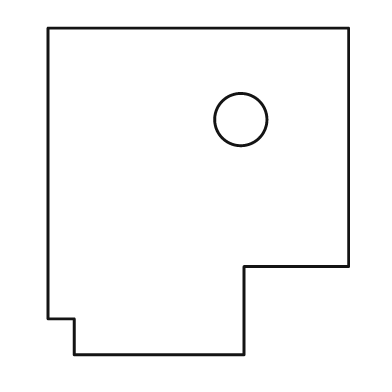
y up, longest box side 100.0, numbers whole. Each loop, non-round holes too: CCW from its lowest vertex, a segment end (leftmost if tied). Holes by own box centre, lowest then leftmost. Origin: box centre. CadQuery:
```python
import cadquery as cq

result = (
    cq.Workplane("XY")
    .moveTo(-38.0, -50.0)
    .lineTo(14.0, -50.0)
    .lineTo(14.0, -23.0)
    .lineTo(46.0, -23.0)
    .lineTo(46.0, 50.0)
    .lineTo(-46.0, 50.0)
    .lineTo(-46.0, -39.0)
    .lineTo(-38.0, -39.0)
    .close()
    .moveTo(13.0, 22.0)
    .circle(8.0)
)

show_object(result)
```